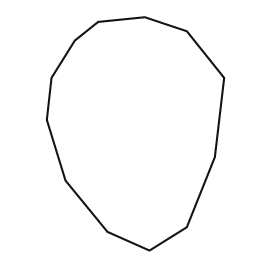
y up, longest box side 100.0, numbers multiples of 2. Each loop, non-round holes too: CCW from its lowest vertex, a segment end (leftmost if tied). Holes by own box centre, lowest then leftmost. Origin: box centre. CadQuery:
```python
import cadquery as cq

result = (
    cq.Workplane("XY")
    .moveTo(6.0, -50.0)
    .lineTo(22.0, -40.0)
    .lineTo(34.0, -10.0)
    .lineTo(38.0, 24.0)
    .lineTo(22.0, 44.0)
    .lineTo(4.0, 50.0)
    .lineTo(-16.0, 48.0)
    .lineTo(-26.0, 40.0)
    .lineTo(-36.0, 24.0)
    .lineTo(-38.0, 6.0)
    .lineTo(-30.0, -20.0)
    .lineTo(-12.0, -42.0)
    .close()
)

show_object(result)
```